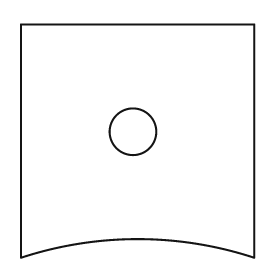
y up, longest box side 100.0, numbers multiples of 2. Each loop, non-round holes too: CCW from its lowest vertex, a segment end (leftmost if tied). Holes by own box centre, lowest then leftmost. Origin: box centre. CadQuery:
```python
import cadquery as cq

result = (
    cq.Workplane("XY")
    .moveTo(-50.0, -50.0)
    .threePointArc((0.0, -42.0), (50.0, -50.0))
    .lineTo(50.0, 50.0)
    .lineTo(-50.0, 50.0)
    .close()
    .moveTo(-2.0, 4.0)
    .circle(10.0)
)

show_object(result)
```